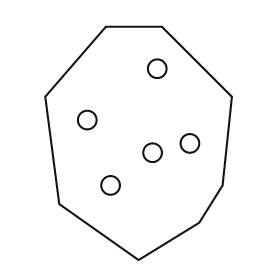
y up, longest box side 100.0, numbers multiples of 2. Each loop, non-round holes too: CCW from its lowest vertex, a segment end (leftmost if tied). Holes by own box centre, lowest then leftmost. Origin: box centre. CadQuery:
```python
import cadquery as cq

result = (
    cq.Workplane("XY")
    .moveTo(0.0, -50.0)
    .lineTo(26.0, -34.0)
    .lineTo(36.0, -18.0)
    .lineTo(40.0, 20.0)
    .lineTo(10.0, 50.0)
    .lineTo(-14.0, 50.0)
    .lineTo(-40.0, 20.0)
    .lineTo(-34.0, -26.0)
    .close()
    .moveTo(-12.0, -18.0)
    .circle(4.0)
    .moveTo(6.0, -4.0)
    .circle(4.0)
    .moveTo(22.0, 0.0)
    .circle(4.0)
    .moveTo(-22.0, 10.0)
    .circle(4.0)
    .moveTo(8.0, 32.0)
    .circle(4.0)
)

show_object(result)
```